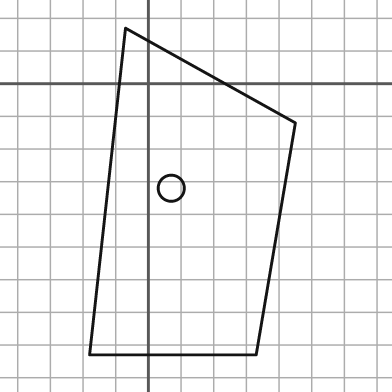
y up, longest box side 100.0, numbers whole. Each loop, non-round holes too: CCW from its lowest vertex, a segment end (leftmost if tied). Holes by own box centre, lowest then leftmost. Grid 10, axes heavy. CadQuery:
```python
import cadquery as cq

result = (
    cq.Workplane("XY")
    .moveTo(-18.0, -83.0)
    .lineTo(33.0, -83.0)
    .lineTo(45.0, -12.0)
    .lineTo(-7.0, 17.0)
    .close()
    .moveTo(7.0, -32.0)
    .circle(4.0)
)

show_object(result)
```